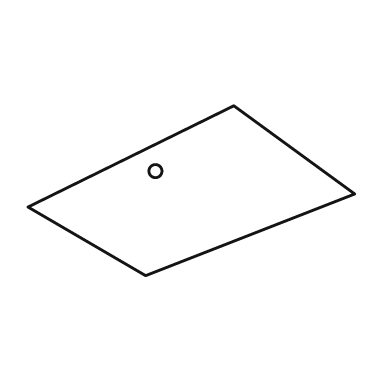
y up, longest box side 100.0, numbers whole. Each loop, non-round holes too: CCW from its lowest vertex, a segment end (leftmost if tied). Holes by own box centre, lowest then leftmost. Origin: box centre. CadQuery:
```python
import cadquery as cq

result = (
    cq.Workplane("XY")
    .moveTo(-14.0, -26.0)
    .lineTo(50.0, -1.0)
    .lineTo(13.0, 26.0)
    .lineTo(-50.0, -5.0)
    .close()
    .moveTo(-11.0, 6.0)
    .circle(2.0)
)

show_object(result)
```